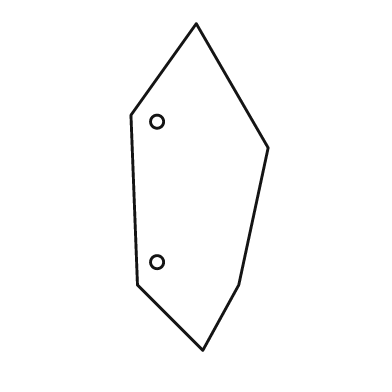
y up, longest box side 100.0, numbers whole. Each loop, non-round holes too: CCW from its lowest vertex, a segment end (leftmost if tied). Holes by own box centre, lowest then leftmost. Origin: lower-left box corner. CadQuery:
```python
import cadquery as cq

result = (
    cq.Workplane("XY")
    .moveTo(22.0, 0.0)
    .lineTo(33.0, 20.0)
    .lineTo(42.0, 62.0)
    .lineTo(20.0, 100.0)
    .lineTo(0.0, 72.0)
    .lineTo(2.0, 20.0)
    .close()
    .moveTo(8.0, 27.0)
    .circle(2.0)
    .moveTo(8.0, 70.0)
    .circle(2.0)
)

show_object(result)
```